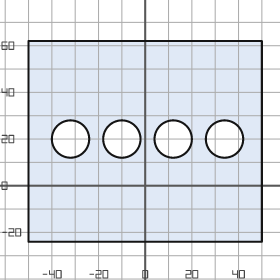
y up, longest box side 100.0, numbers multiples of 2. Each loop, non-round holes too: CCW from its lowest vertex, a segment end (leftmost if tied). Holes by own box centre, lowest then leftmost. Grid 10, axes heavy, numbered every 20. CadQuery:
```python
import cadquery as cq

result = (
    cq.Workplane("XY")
    .moveTo(-50.0, -24.0)
    .lineTo(50.0, -24.0)
    .lineTo(50.0, 62.0)
    .lineTo(-50.0, 62.0)
    .close()
    .moveTo(-32.0, 20.0)
    .circle(8.0)
    .moveTo(-10.0, 20.0)
    .circle(8.0)
    .moveTo(12.0, 20.0)
    .circle(8.0)
    .moveTo(34.0, 20.0)
    .circle(8.0)
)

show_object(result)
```